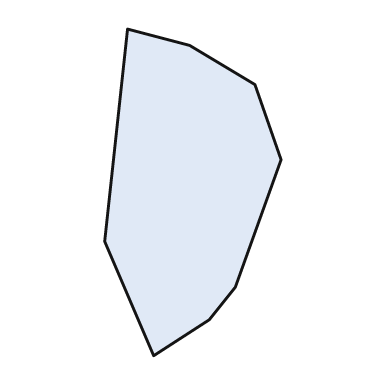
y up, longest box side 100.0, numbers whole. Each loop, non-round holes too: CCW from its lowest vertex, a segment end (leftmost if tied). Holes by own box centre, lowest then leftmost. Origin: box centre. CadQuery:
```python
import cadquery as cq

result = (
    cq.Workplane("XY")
    .moveTo(-12.0, -50.0)
    .lineTo(5.0, -39.0)
    .lineTo(13.0, -29.0)
    .lineTo(27.0, 10.0)
    .lineTo(19.0, 33.0)
    .lineTo(-1.0, 45.0)
    .lineTo(-20.0, 50.0)
    .lineTo(-27.0, -15.0)
    .close()
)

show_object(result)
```